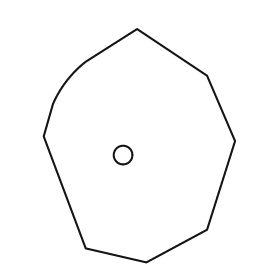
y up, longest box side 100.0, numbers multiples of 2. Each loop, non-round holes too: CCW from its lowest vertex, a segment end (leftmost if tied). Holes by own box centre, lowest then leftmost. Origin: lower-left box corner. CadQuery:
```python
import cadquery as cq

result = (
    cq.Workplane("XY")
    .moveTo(44.0, 0.0)
    .lineTo(70.0, 14.0)
    .lineTo(82.0, 52.0)
    .lineTo(70.0, 80.0)
    .lineTo(40.0, 100.0)
    .lineTo(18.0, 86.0)
    .threePointArc((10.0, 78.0), (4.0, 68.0))
    .lineTo(0.0, 54.0)
    .lineTo(18.0, 6.0)
    .close()
    .moveTo(34.0, 46.0)
    .circle(4.0)
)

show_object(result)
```